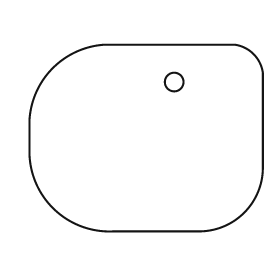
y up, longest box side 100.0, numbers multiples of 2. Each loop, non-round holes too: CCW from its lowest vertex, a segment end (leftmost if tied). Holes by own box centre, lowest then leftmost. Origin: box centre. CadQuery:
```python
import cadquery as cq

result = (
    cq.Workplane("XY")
    .moveTo(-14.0, -40.0)
    .lineTo(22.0, -40.0)
    .threePointArc((42.0, -32.0), (50.0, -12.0))
    .lineTo(50.0, 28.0)
    .threePointArc((46.0, 36.0), (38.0, 40.0))
    .lineTo(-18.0, 40.0)
    .threePointArc((-40.0, 30.0), (-50.0, 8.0))
    .lineTo(-50.0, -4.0)
    .threePointArc((-40.0, -30.0), (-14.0, -40.0))
    .close()
    .moveTo(12.0, 24.0)
    .circle(4.0)
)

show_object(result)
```